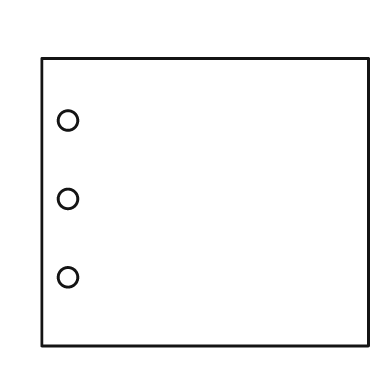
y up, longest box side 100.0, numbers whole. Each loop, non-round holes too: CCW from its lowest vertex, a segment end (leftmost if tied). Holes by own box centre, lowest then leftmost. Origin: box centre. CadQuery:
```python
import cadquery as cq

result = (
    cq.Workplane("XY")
    .moveTo(-50.0, -44.0)
    .lineTo(50.0, -44.0)
    .lineTo(50.0, 44.0)
    .lineTo(-50.0, 44.0)
    .close()
    .moveTo(-42.0, -23.0)
    .circle(3.0)
    .moveTo(-42.0, 1.0)
    .circle(3.0)
    .moveTo(-42.0, 25.0)
    .circle(3.0)
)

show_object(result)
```